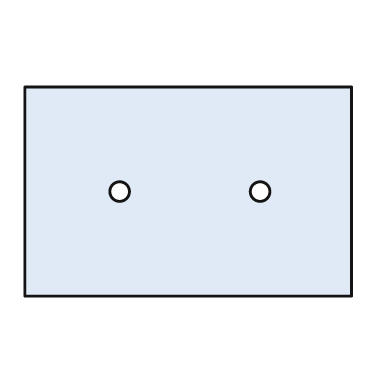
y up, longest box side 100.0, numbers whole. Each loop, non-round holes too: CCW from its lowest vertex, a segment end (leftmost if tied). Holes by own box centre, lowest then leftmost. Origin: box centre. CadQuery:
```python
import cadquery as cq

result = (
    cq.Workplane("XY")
    .moveTo(-50.0, -32.0)
    .lineTo(50.0, -32.0)
    .lineTo(50.0, 32.0)
    .lineTo(-50.0, 32.0)
    .close()
    .moveTo(-21.0, 0.0)
    .circle(3.0)
    .moveTo(22.0, 0.0)
    .circle(3.0)
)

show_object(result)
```